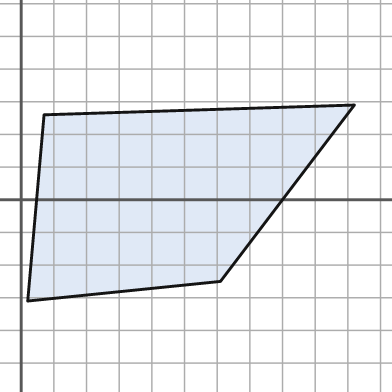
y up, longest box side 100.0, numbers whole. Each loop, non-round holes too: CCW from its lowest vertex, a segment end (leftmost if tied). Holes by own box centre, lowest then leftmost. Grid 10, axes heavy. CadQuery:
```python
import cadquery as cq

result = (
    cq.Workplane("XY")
    .moveTo(2.0, -31.0)
    .lineTo(61.0, -25.0)
    .lineTo(102.0, 29.0)
    .lineTo(7.0, 26.0)
    .close()
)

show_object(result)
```